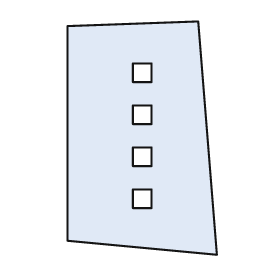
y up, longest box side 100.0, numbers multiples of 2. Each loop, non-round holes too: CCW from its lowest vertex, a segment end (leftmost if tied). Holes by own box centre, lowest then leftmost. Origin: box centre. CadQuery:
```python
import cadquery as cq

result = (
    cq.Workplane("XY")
    .moveTo(32.0, -50.0)
    .lineTo(24.0, 50.0)
    .lineTo(-32.0, 48.0)
    .lineTo(-32.0, -44.0)
    .close()
    .moveTo(-4.0, -30.0)
    .lineTo(4.0, -30.0)
    .lineTo(4.0, -22.0)
    .lineTo(-4.0, -22.0)
    .close()
    .moveTo(-4.0, -12.0)
    .lineTo(4.0, -12.0)
    .lineTo(4.0, -4.0)
    .lineTo(-4.0, -4.0)
    .close()
    .moveTo(-4.0, 6.0)
    .lineTo(4.0, 6.0)
    .lineTo(4.0, 14.0)
    .lineTo(-4.0, 14.0)
    .close()
    .moveTo(-4.0, 24.0)
    .lineTo(4.0, 24.0)
    .lineTo(4.0, 32.0)
    .lineTo(-4.0, 32.0)
    .close()
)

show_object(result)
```